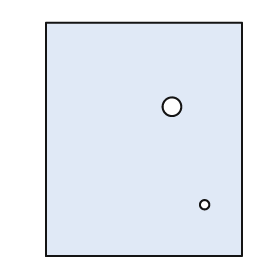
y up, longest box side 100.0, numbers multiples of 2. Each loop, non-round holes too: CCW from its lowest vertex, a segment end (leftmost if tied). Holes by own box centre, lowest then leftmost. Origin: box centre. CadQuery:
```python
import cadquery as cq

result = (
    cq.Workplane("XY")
    .moveTo(-42.0, -50.0)
    .lineTo(42.0, -50.0)
    .lineTo(42.0, 50.0)
    .lineTo(-42.0, 50.0)
    .close()
    .moveTo(26.0, -28.0)
    .circle(2.0)
    .moveTo(12.0, 14.0)
    .circle(4.0)
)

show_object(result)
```